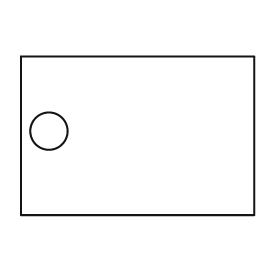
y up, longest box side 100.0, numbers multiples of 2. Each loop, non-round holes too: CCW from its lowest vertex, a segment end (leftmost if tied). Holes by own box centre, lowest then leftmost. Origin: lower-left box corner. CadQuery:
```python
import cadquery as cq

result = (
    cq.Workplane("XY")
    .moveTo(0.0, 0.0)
    .lineTo(100.0, 0.0)
    .lineTo(100.0, 68.0)
    .lineTo(0.0, 68.0)
    .close()
    .moveTo(12.0, 36.0)
    .circle(8.0)
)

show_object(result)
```